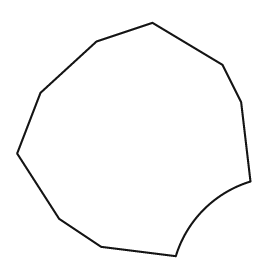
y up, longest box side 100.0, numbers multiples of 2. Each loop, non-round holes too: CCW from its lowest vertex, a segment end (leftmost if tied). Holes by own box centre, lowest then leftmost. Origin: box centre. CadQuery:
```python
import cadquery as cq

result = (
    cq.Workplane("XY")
    .moveTo(18.0, -50.0)
    .threePointArc((30.0, -30.0), (50.0, -18.0))
    .lineTo(46.0, 16.0)
    .lineTo(38.0, 32.0)
    .lineTo(8.0, 50.0)
    .lineTo(-16.0, 42.0)
    .lineTo(-40.0, 20.0)
    .lineTo(-50.0, -6.0)
    .lineTo(-32.0, -34.0)
    .lineTo(-14.0, -46.0)
    .close()
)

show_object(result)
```